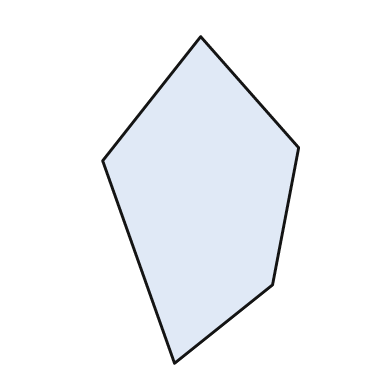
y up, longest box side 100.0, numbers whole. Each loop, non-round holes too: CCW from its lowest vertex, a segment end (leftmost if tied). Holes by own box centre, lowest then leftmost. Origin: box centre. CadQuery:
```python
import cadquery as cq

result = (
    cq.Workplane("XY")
    .moveTo(-8.0, -50.0)
    .lineTo(22.0, -26.0)
    .lineTo(30.0, 16.0)
    .lineTo(0.0, 50.0)
    .lineTo(-30.0, 12.0)
    .close()
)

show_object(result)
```